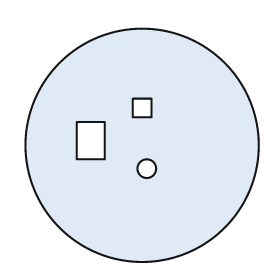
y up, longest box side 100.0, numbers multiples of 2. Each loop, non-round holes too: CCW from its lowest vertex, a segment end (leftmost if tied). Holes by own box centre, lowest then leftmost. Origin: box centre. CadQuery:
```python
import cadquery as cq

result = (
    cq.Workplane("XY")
    .moveTo(0.0, 0.0)
    .circle(50.0)
    .moveTo(2.0, -10.0)
    .circle(4.0)
    .moveTo(-28.0, -6.0)
    .lineTo(-16.0, -6.0)
    .lineTo(-16.0, 10.0)
    .lineTo(-28.0, 10.0)
    .close()
    .moveTo(-4.0, 12.0)
    .lineTo(4.0, 12.0)
    .lineTo(4.0, 20.0)
    .lineTo(-4.0, 20.0)
    .close()
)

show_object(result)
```